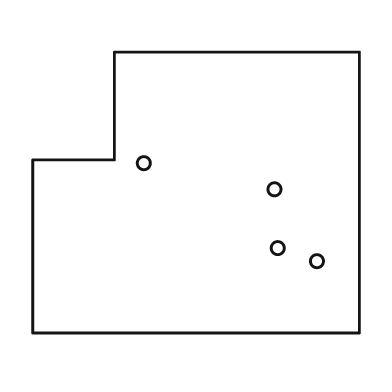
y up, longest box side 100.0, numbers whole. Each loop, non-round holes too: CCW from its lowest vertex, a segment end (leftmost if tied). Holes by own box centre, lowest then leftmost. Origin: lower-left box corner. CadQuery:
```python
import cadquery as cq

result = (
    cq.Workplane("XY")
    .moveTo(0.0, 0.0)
    .lineTo(100.0, 0.0)
    .lineTo(100.0, 86.0)
    .lineTo(25.0, 86.0)
    .lineTo(25.0, 53.0)
    .lineTo(0.0, 53.0)
    .close()
    .moveTo(87.0, 22.0)
    .circle(2.0)
    .moveTo(75.0, 26.0)
    .circle(2.0)
    .moveTo(74.0, 44.0)
    .circle(2.0)
    .moveTo(34.0, 52.0)
    .circle(2.0)
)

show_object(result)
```